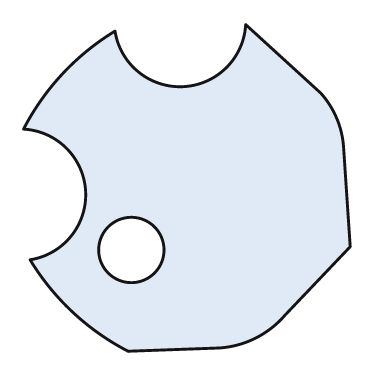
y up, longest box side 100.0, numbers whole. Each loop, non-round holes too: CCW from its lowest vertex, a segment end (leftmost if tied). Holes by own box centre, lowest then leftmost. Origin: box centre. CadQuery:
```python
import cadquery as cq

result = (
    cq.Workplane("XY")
    .moveTo(-18.0, -50.0)
    .lineTo(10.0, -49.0)
    .threePointArc((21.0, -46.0), (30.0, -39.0))
    .lineTo(50.0, -18.0)
    .lineTo(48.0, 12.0)
    .threePointArc((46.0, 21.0), (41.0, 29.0))
    .lineTo(18.0, 50.0)
    .threePointArc((-1.0, 31.0), (-22.0, 48.0))
    .threePointArc((-38.0, 35.0), (-50.0, 18.0))
    .threePointArc((-31.0, -1.0), (-48.0, -22.0))
    .threePointArc((-35.0, -38.0), (-18.0, -50.0))
    .close()
    .moveTo(-17.0, -19.0)
    .circle(10.0)
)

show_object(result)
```